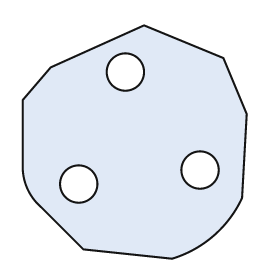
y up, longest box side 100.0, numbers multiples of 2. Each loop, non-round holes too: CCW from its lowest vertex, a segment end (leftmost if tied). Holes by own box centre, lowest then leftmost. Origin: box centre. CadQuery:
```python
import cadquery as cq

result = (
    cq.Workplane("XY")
    .moveTo(16.0, -50.0)
    .threePointArc((34.0, -40.0), (46.0, -24.0))
    .lineTo(48.0, 12.0)
    .lineTo(38.0, 36.0)
    .lineTo(4.0, 50.0)
    .lineTo(-36.0, 32.0)
    .lineTo(-48.0, 18.0)
    .lineTo(-48.0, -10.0)
    .threePointArc((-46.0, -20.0), (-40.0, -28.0))
    .lineTo(-22.0, -46.0)
    .close()
    .moveTo(-24.0, -18.0)
    .circle(8.0)
    .moveTo(28.0, -12.0)
    .circle(8.0)
    .moveTo(-4.0, 30.0)
    .circle(8.0)
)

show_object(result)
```